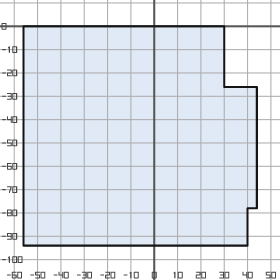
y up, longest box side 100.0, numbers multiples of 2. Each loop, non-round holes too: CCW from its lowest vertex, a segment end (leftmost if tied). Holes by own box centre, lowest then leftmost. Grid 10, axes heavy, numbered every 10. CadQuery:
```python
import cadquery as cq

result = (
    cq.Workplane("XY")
    .moveTo(-56.0, -94.0)
    .lineTo(40.0, -94.0)
    .lineTo(40.0, -78.0)
    .lineTo(44.0, -78.0)
    .lineTo(44.0, -26.0)
    .lineTo(30.0, -26.0)
    .lineTo(30.0, 0.0)
    .lineTo(-56.0, 0.0)
    .close()
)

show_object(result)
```